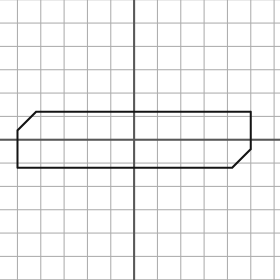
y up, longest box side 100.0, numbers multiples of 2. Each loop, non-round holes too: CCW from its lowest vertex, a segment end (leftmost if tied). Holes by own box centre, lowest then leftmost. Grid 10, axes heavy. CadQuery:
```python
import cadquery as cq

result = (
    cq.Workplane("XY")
    .moveTo(-50.0, -12.0)
    .lineTo(42.0, -12.0)
    .lineTo(50.0, -4.0)
    .lineTo(50.0, 12.0)
    .lineTo(-42.0, 12.0)
    .lineTo(-50.0, 4.0)
    .close()
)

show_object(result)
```